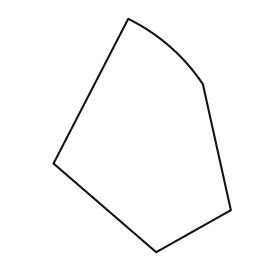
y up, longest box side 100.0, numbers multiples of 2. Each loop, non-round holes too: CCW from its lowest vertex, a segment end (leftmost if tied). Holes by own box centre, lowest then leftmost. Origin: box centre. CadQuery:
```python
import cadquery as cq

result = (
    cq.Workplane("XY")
    .moveTo(6.0, -50.0)
    .lineTo(38.0, -32.0)
    .lineTo(26.0, 22.0)
    .threePointArc((12.0, 38.0), (-6.0, 50.0))
    .lineTo(-38.0, -12.0)
    .close()
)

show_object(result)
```